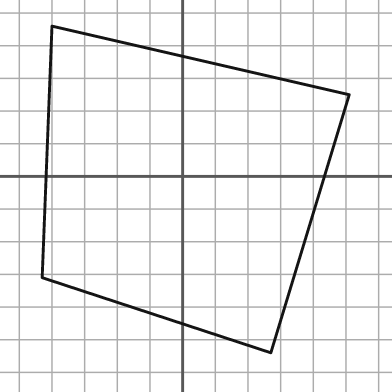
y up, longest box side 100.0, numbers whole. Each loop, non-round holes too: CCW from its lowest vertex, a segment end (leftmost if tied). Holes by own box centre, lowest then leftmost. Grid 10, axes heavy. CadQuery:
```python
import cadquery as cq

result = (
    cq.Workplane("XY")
    .moveTo(27.0, -54.0)
    .lineTo(51.0, 25.0)
    .lineTo(-40.0, 46.0)
    .lineTo(-43.0, -31.0)
    .close()
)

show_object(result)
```